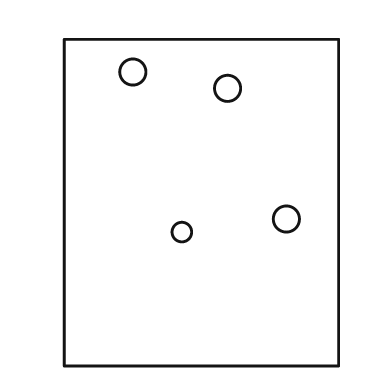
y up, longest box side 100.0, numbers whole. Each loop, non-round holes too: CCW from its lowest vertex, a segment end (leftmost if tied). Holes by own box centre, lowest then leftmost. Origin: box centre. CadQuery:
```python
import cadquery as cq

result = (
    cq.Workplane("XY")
    .moveTo(-42.0, -50.0)
    .lineTo(42.0, -50.0)
    .lineTo(42.0, 50.0)
    .lineTo(-42.0, 50.0)
    .close()
    .moveTo(-6.0, -9.0)
    .circle(3.0)
    .moveTo(26.0, -5.0)
    .circle(4.0)
    .moveTo(8.0, 35.0)
    .circle(4.0)
    .moveTo(-21.0, 40.0)
    .circle(4.0)
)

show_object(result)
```